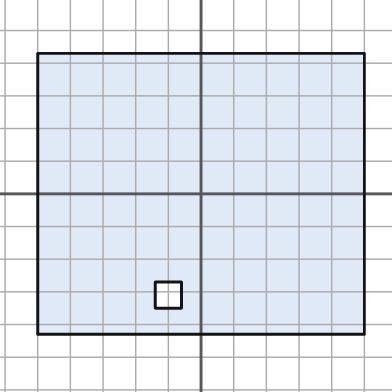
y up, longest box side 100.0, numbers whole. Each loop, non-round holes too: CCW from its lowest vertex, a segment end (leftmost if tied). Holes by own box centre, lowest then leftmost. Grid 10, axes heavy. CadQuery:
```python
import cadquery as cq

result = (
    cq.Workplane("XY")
    .moveTo(-50.0, -43.0)
    .lineTo(50.0, -43.0)
    .lineTo(50.0, 43.0)
    .lineTo(-50.0, 43.0)
    .close()
    .moveTo(-14.0, -35.0)
    .lineTo(-6.0, -35.0)
    .lineTo(-6.0, -27.0)
    .lineTo(-14.0, -27.0)
    .close()
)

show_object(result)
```